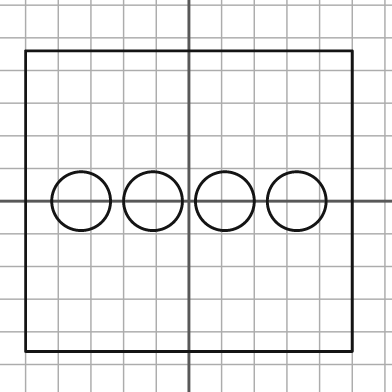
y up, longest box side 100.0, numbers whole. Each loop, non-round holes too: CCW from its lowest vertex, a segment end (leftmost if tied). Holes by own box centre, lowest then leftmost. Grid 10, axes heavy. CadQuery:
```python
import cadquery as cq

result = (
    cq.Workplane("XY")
    .moveTo(-50.0, -46.0)
    .lineTo(50.0, -46.0)
    .lineTo(50.0, 46.0)
    .lineTo(-50.0, 46.0)
    .close()
    .moveTo(-33.0, 0.0)
    .circle(9.0)
    .moveTo(-11.0, 0.0)
    .circle(9.0)
    .moveTo(11.0, 0.0)
    .circle(9.0)
    .moveTo(33.0, 0.0)
    .circle(9.0)
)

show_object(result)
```